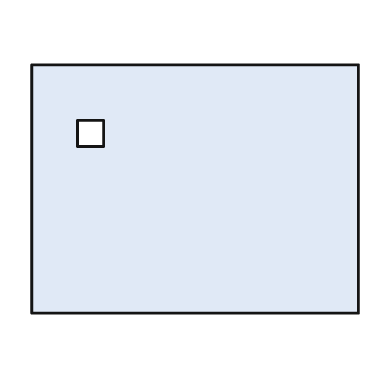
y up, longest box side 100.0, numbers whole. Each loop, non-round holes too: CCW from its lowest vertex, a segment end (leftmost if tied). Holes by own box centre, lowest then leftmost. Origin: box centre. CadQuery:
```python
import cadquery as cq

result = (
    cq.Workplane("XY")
    .moveTo(-50.0, -38.0)
    .lineTo(50.0, -38.0)
    .lineTo(50.0, 38.0)
    .lineTo(-50.0, 38.0)
    .close()
    .moveTo(-36.0, 13.0)
    .lineTo(-28.0, 13.0)
    .lineTo(-28.0, 21.0)
    .lineTo(-36.0, 21.0)
    .close()
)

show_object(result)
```